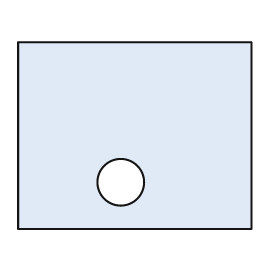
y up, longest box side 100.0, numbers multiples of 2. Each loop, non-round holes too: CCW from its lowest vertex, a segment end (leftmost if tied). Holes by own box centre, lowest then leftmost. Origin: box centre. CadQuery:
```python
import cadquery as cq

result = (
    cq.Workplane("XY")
    .moveTo(-50.0, -40.0)
    .lineTo(50.0, -40.0)
    .lineTo(50.0, 40.0)
    .lineTo(-50.0, 40.0)
    .close()
    .moveTo(-6.0, -20.0)
    .circle(10.0)
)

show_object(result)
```